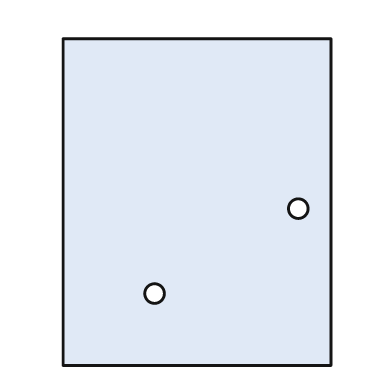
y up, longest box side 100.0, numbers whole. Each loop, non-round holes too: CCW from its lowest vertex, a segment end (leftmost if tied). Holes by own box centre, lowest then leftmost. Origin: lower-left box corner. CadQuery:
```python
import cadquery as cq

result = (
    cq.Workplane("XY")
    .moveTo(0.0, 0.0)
    .lineTo(82.0, 0.0)
    .lineTo(82.0, 100.0)
    .lineTo(0.0, 100.0)
    .close()
    .moveTo(28.0, 22.0)
    .circle(3.0)
    .moveTo(72.0, 48.0)
    .circle(3.0)
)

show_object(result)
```